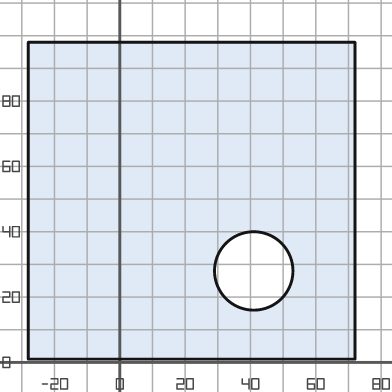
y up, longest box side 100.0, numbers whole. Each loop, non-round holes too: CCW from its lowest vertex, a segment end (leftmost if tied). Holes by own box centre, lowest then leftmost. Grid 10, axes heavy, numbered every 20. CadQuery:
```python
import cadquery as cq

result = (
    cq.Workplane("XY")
    .moveTo(-28.0, 1.0)
    .lineTo(72.0, 1.0)
    .lineTo(72.0, 98.0)
    .lineTo(-28.0, 98.0)
    .close()
    .moveTo(41.0, 28.0)
    .circle(12.0)
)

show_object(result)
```